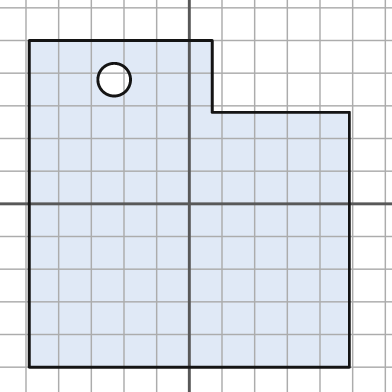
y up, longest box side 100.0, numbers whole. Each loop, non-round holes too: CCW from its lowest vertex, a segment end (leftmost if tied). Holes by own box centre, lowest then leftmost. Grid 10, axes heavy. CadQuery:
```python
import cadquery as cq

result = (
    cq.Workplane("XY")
    .moveTo(-49.0, -50.0)
    .lineTo(49.0, -50.0)
    .lineTo(49.0, 28.0)
    .lineTo(7.0, 28.0)
    .lineTo(7.0, 50.0)
    .lineTo(-49.0, 50.0)
    .close()
    .moveTo(-23.0, 38.0)
    .circle(5.0)
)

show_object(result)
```